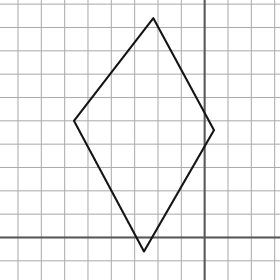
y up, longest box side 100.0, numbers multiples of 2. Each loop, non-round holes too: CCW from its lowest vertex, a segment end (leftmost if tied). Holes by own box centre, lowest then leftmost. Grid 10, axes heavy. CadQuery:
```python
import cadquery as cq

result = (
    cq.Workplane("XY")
    .moveTo(-26.0, -6.0)
    .lineTo(4.0, 46.0)
    .lineTo(-22.0, 94.0)
    .lineTo(-56.0, 50.0)
    .close()
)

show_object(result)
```